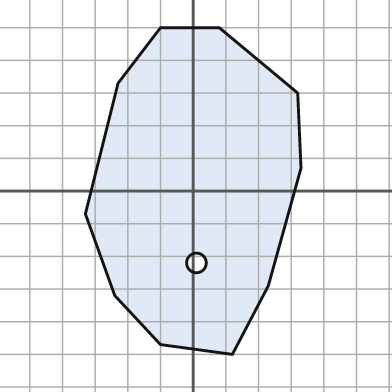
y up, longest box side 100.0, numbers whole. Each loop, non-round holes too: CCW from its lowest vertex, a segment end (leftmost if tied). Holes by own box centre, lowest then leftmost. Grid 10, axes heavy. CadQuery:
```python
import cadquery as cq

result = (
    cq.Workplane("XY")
    .moveTo(12.0, -50.0)
    .lineTo(23.0, -29.0)
    .lineTo(33.0, 7.0)
    .lineTo(32.0, 30.0)
    .lineTo(8.0, 50.0)
    .lineTo(-10.0, 50.0)
    .lineTo(-23.0, 33.0)
    .lineTo(-33.0, -7.0)
    .lineTo(-24.0, -32.0)
    .lineTo(-10.0, -47.0)
    .close()
    .moveTo(1.0, -22.0)
    .circle(3.0)
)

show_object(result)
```